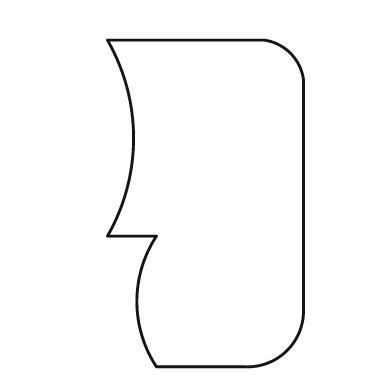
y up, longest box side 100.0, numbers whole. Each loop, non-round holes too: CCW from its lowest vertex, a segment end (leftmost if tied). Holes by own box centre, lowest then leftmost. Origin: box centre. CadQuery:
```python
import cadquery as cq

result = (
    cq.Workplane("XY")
    .moveTo(-15.0, -50.0)
    .lineTo(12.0, -50.0)
    .threePointArc((25.0, -45.0), (30.0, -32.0))
    .lineTo(30.0, 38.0)
    .threePointArc((26.0, 46.0), (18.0, 50.0))
    .lineTo(-30.0, 50.0)
    .threePointArc((-22.0, 20.0), (-30.0, -10.0))
    .lineTo(-15.0, -10.0)
    .threePointArc((-21.0, -30.0), (-15.0, -50.0))
    .close()
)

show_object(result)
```